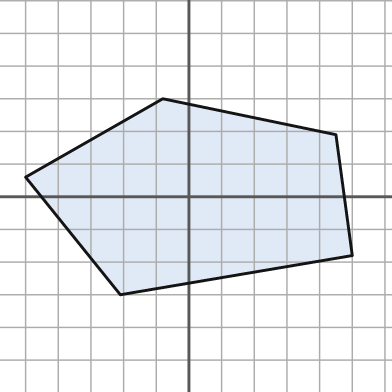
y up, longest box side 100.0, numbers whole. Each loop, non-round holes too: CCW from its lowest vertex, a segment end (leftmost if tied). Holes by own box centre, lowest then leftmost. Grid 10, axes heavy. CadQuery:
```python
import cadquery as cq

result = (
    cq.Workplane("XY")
    .moveTo(-21.0, -30.0)
    .lineTo(50.0, -18.0)
    .lineTo(45.0, 19.0)
    .lineTo(-8.0, 30.0)
    .lineTo(-50.0, 6.0)
    .close()
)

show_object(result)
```